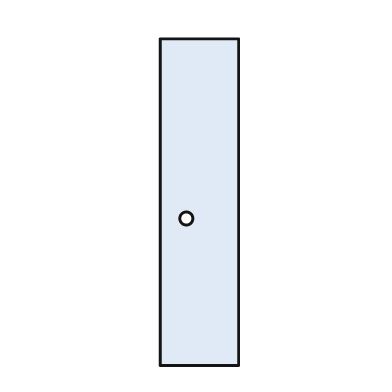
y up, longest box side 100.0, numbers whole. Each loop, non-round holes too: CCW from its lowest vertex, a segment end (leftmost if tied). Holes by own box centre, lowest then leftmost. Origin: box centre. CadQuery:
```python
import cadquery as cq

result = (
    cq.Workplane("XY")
    .moveTo(-12.0, -50.0)
    .lineTo(12.0, -50.0)
    .lineTo(12.0, 50.0)
    .lineTo(-12.0, 50.0)
    .close()
    .moveTo(-4.0, -5.0)
    .circle(2.0)
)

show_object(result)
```